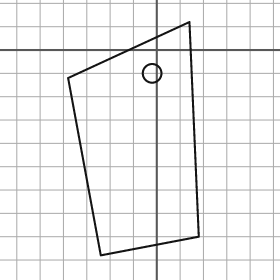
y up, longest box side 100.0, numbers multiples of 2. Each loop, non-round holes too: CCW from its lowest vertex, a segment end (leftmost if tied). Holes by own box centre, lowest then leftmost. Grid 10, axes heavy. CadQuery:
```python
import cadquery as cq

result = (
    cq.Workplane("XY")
    .moveTo(-24.0, -88.0)
    .lineTo(18.0, -80.0)
    .lineTo(14.0, 12.0)
    .lineTo(-38.0, -12.0)
    .close()
    .moveTo(-2.0, -10.0)
    .circle(4.0)
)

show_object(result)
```